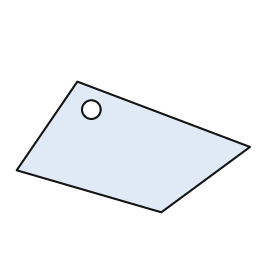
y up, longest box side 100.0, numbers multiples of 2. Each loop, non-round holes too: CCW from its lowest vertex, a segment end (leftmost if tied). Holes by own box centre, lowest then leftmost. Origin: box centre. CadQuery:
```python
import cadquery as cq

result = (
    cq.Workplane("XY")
    .moveTo(12.0, -28.0)
    .lineTo(50.0, 0.0)
    .lineTo(-24.0, 28.0)
    .lineTo(-50.0, -10.0)
    .close()
    .moveTo(-18.0, 16.0)
    .circle(4.0)
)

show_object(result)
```